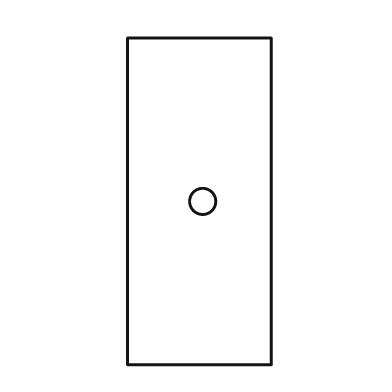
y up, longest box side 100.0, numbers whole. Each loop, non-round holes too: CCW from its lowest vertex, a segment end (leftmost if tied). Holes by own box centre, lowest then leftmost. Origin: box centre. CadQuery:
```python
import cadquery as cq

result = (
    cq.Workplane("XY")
    .moveTo(-22.0, -50.0)
    .lineTo(22.0, -50.0)
    .lineTo(22.0, 50.0)
    .lineTo(-22.0, 50.0)
    .close()
    .moveTo(1.0, 0.0)
    .circle(4.0)
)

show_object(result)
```